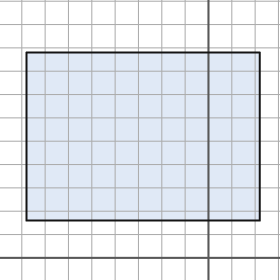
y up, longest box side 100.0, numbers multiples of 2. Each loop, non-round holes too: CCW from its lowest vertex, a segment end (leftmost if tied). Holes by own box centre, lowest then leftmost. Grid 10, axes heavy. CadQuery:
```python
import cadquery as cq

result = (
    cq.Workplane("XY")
    .moveTo(-78.0, 16.0)
    .lineTo(22.0, 16.0)
    .lineTo(22.0, 88.0)
    .lineTo(-78.0, 88.0)
    .close()
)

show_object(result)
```